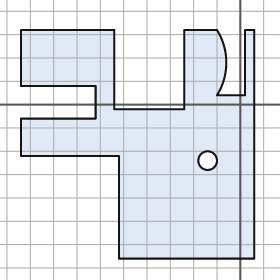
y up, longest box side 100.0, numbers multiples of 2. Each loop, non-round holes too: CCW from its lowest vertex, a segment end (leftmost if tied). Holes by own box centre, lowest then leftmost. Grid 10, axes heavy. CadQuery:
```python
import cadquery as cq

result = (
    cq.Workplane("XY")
    .moveTo(-52.0, -66.0)
    .lineTo(6.0, -66.0)
    .lineTo(6.0, 32.0)
    .lineTo(2.0, 32.0)
    .lineTo(2.0, 4.0)
    .lineTo(-10.0, 4.0)
    .threePointArc((-6.0, 18.0), (-10.0, 32.0))
    .lineTo(-24.0, 32.0)
    .lineTo(-24.0, -2.0)
    .lineTo(-54.0, -2.0)
    .lineTo(-54.0, 32.0)
    .lineTo(-94.0, 32.0)
    .lineTo(-94.0, 8.0)
    .lineTo(-62.0, 8.0)
    .lineTo(-62.0, -6.0)
    .lineTo(-94.0, -6.0)
    .lineTo(-94.0, -22.0)
    .lineTo(-52.0, -22.0)
    .close()
    .moveTo(-14.0, -24.0)
    .circle(4.0)
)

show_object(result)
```